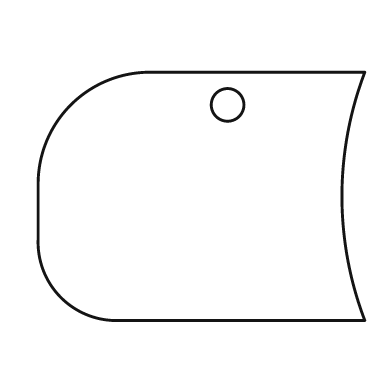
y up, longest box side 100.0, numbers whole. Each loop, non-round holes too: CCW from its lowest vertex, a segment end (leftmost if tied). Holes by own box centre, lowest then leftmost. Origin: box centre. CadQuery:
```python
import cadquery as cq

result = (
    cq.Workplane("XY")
    .moveTo(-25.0, -38.0)
    .lineTo(50.0, -38.0)
    .threePointArc((43.0, 0.0), (50.0, 38.0))
    .lineTo(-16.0, 38.0)
    .threePointArc((-40.0, 28.0), (-50.0, 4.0))
    .lineTo(-50.0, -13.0)
    .threePointArc((-43.0, -31.0), (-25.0, -38.0))
    .close()
    .moveTo(8.0, 28.0)
    .circle(5.0)
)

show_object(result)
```